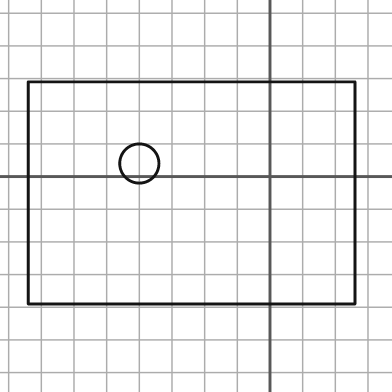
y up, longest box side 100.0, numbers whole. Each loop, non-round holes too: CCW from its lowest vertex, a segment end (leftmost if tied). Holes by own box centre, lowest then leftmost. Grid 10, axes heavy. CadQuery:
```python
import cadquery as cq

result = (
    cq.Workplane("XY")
    .moveTo(-74.0, -39.0)
    .lineTo(26.0, -39.0)
    .lineTo(26.0, 29.0)
    .lineTo(-74.0, 29.0)
    .close()
    .moveTo(-40.0, 4.0)
    .circle(6.0)
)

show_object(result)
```